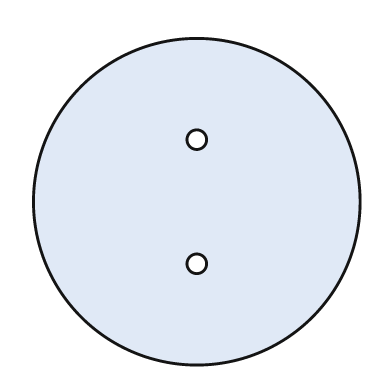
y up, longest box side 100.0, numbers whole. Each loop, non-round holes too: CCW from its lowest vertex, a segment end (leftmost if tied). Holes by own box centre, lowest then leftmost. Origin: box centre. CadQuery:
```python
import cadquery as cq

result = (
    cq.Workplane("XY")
    .moveTo(0.0, 0.0)
    .circle(50.0)
    .moveTo(0.0, -19.0)
    .circle(3.0)
    .moveTo(0.0, 19.0)
    .circle(3.0)
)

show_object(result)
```